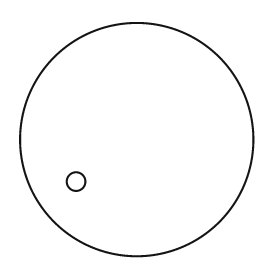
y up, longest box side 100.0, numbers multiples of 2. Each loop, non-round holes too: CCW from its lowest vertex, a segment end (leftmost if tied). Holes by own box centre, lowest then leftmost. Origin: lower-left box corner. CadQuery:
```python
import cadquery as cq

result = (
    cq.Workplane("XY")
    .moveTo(50.0, 50.0)
    .circle(50.0)
    .moveTo(24.0, 32.0)
    .circle(4.0)
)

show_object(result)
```